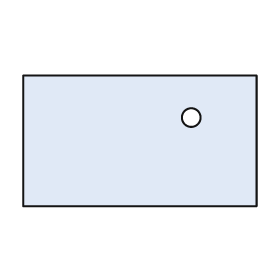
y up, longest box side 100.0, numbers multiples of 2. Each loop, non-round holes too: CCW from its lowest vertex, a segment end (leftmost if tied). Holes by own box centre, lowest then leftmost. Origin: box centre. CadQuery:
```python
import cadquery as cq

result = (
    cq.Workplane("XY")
    .moveTo(-50.0, -28.0)
    .lineTo(50.0, -28.0)
    .lineTo(50.0, 28.0)
    .lineTo(-50.0, 28.0)
    .close()
    .moveTo(22.0, 10.0)
    .circle(4.0)
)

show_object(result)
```